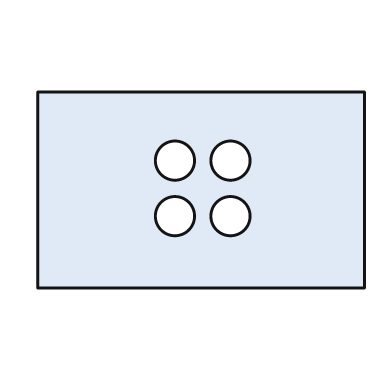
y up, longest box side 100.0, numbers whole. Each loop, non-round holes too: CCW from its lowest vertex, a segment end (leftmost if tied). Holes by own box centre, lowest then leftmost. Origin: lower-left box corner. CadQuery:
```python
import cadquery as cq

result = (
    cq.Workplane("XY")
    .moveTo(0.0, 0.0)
    .lineTo(100.0, 0.0)
    .lineTo(100.0, 60.0)
    .lineTo(0.0, 60.0)
    .close()
    .moveTo(42.0, 22.0)
    .circle(6.0)
    .moveTo(59.0, 22.0)
    .circle(6.0)
    .moveTo(42.0, 39.0)
    .circle(6.0)
    .moveTo(59.0, 39.0)
    .circle(6.0)
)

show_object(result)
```